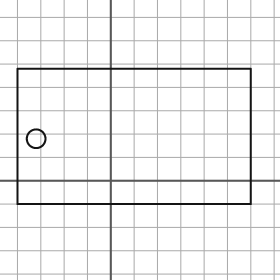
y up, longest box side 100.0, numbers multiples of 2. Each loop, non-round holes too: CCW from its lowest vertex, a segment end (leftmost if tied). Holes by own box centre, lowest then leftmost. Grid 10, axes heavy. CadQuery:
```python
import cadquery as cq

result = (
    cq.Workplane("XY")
    .moveTo(-40.0, -10.0)
    .lineTo(60.0, -10.0)
    .lineTo(60.0, 48.0)
    .lineTo(-40.0, 48.0)
    .close()
    .moveTo(-32.0, 18.0)
    .circle(4.0)
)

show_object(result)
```